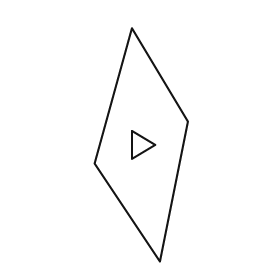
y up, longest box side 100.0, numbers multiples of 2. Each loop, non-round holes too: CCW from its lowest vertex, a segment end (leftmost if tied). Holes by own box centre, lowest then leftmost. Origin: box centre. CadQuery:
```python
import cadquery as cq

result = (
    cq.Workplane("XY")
    .moveTo(8.0, -50.0)
    .lineTo(20.0, 10.0)
    .lineTo(-4.0, 50.0)
    .lineTo(-20.0, -8.0)
    .close()
    .moveTo(-4.0, -6.0)
    .lineTo(6.0, 0.0)
    .lineTo(-4.0, 6.0)
    .close()
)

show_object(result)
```